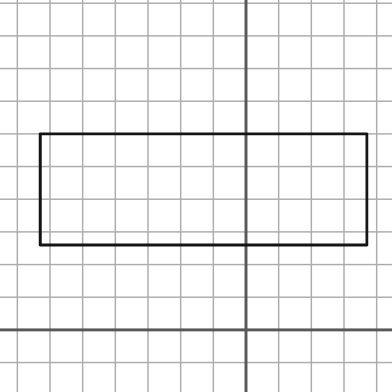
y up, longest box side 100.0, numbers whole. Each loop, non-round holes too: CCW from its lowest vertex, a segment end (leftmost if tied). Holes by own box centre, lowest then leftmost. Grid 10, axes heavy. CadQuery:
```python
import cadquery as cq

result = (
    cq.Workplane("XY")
    .moveTo(-63.0, 26.0)
    .lineTo(37.0, 26.0)
    .lineTo(37.0, 60.0)
    .lineTo(-63.0, 60.0)
    .close()
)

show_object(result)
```